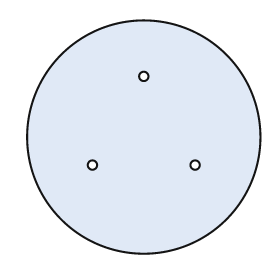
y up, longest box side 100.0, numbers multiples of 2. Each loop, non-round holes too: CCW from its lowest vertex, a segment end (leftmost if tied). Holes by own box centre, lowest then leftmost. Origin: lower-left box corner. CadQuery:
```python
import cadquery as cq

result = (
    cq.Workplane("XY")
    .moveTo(50.0, 50.0)
    .circle(50.0)
    .moveTo(28.0, 38.0)
    .circle(2.0)
    .moveTo(72.0, 38.0)
    .circle(2.0)
    .moveTo(50.0, 76.0)
    .circle(2.0)
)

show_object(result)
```